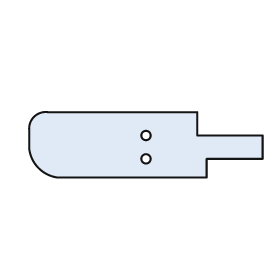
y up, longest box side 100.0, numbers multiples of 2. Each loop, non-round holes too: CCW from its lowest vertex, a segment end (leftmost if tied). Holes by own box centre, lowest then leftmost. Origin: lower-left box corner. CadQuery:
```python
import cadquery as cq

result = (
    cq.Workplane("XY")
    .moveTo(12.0, 0.0)
    .lineTo(76.0, 0.0)
    .lineTo(76.0, 8.0)
    .lineTo(100.0, 8.0)
    .lineTo(100.0, 18.0)
    .lineTo(72.0, 18.0)
    .lineTo(72.0, 28.0)
    .lineTo(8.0, 28.0)
    .threePointArc((2.0, 26.0), (0.0, 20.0))
    .lineTo(0.0, 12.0)
    .threePointArc((4.0, 4.0), (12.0, 0.0))
    .close()
    .moveTo(50.0, 8.0)
    .circle(2.0)
    .moveTo(50.0, 18.0)
    .circle(2.0)
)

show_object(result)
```